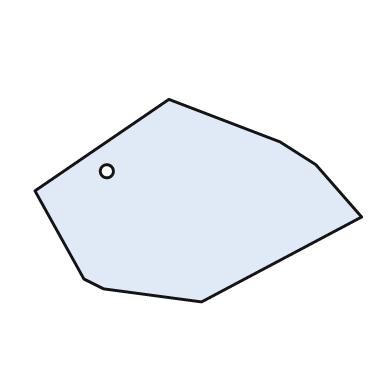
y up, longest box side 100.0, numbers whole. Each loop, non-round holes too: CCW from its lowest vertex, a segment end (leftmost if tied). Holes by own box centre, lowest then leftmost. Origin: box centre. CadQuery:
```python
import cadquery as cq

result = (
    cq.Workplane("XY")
    .moveTo(1.0, -31.0)
    .lineTo(50.0, -5.0)
    .lineTo(36.0, 11.0)
    .lineTo(25.0, 18.0)
    .lineTo(-9.0, 31.0)
    .lineTo(-50.0, 3.0)
    .lineTo(-35.0, -24.0)
    .lineTo(-29.0, -27.0)
    .close()
    .moveTo(-28.0, 9.0)
    .circle(2.0)
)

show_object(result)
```